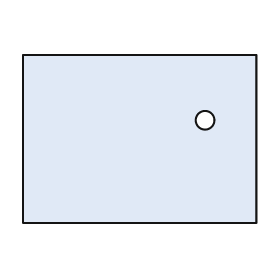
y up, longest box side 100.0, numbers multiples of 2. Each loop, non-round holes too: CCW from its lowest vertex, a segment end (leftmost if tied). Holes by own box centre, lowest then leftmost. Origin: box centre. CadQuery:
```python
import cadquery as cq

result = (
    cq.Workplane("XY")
    .moveTo(-50.0, -36.0)
    .lineTo(50.0, -36.0)
    .lineTo(50.0, 36.0)
    .lineTo(-50.0, 36.0)
    .close()
    .moveTo(28.0, 8.0)
    .circle(4.0)
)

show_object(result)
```